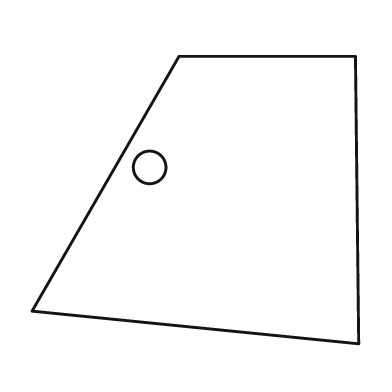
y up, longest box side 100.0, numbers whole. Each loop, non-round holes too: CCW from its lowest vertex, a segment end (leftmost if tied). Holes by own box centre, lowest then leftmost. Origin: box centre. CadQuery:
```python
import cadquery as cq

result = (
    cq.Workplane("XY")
    .moveTo(50.0, -44.0)
    .lineTo(49.0, 44.0)
    .lineTo(-5.0, 44.0)
    .lineTo(-50.0, -34.0)
    .close()
    .moveTo(-14.0, 10.0)
    .circle(5.0)
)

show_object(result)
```